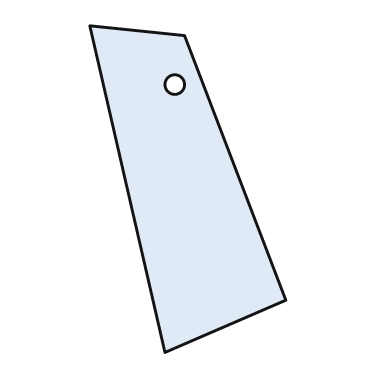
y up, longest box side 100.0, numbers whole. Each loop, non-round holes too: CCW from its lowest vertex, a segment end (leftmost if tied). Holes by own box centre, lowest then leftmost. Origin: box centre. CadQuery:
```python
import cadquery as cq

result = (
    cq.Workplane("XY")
    .moveTo(-7.0, -50.0)
    .lineTo(30.0, -34.0)
    .lineTo(-1.0, 47.0)
    .lineTo(-30.0, 50.0)
    .close()
    .moveTo(-4.0, 32.0)
    .circle(3.0)
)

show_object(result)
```